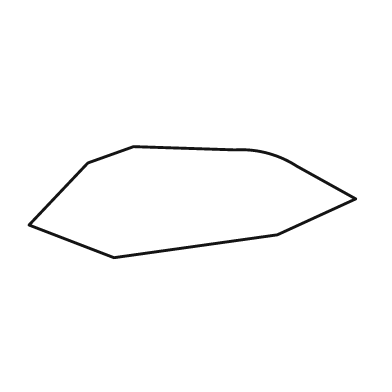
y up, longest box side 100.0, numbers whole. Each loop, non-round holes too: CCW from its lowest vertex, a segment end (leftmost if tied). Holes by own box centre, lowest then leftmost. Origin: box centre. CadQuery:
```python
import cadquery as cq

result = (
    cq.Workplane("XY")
    .moveTo(-24.0, -17.0)
    .lineTo(26.0, -10.0)
    .lineTo(50.0, 1.0)
    .lineTo(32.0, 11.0)
    .threePointArc((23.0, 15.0), (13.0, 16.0))
    .lineTo(-18.0, 17.0)
    .lineTo(-32.0, 12.0)
    .lineTo(-50.0, -7.0)
    .close()
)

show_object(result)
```